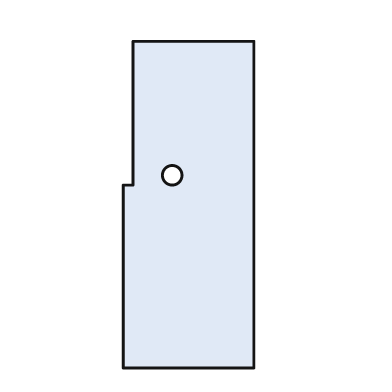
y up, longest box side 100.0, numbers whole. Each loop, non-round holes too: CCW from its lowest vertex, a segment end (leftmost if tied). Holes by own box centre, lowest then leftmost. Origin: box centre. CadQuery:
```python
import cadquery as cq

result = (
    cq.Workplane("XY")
    .moveTo(-20.0, -50.0)
    .lineTo(20.0, -50.0)
    .lineTo(20.0, 50.0)
    .lineTo(-17.0, 50.0)
    .lineTo(-17.0, 6.0)
    .lineTo(-20.0, 6.0)
    .close()
    .moveTo(-5.0, 9.0)
    .circle(3.0)
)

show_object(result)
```